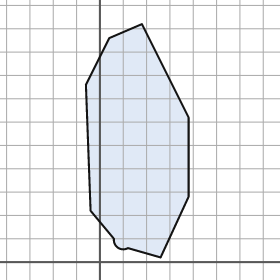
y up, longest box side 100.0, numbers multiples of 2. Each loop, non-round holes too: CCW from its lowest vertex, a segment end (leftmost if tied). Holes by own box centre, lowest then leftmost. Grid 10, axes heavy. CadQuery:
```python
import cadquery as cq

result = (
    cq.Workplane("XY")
    .moveTo(26.0, 2.0)
    .lineTo(38.0, 28.0)
    .lineTo(38.0, 62.0)
    .lineTo(18.0, 102.0)
    .lineTo(4.0, 96.0)
    .lineTo(-6.0, 76.0)
    .lineTo(-4.0, 22.0)
    .lineTo(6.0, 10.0)
    .threePointArc((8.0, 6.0), (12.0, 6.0))
    .close()
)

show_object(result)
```